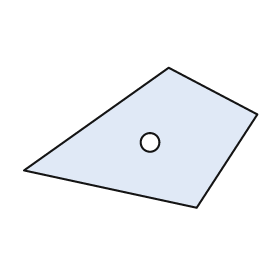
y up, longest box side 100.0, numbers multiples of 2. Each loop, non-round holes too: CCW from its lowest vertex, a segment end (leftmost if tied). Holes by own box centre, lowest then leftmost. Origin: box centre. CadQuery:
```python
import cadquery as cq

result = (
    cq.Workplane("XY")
    .moveTo(24.0, -30.0)
    .lineTo(50.0, 10.0)
    .lineTo(12.0, 30.0)
    .lineTo(-50.0, -14.0)
    .close()
    .moveTo(4.0, -2.0)
    .circle(4.0)
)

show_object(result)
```